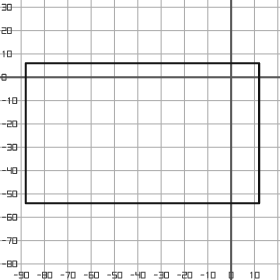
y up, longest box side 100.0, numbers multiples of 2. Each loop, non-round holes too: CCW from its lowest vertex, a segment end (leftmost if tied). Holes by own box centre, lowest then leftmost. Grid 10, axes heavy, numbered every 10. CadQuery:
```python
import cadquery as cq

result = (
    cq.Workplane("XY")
    .moveTo(-88.0, -54.0)
    .lineTo(12.0, -54.0)
    .lineTo(12.0, 6.0)
    .lineTo(-88.0, 6.0)
    .close()
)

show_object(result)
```